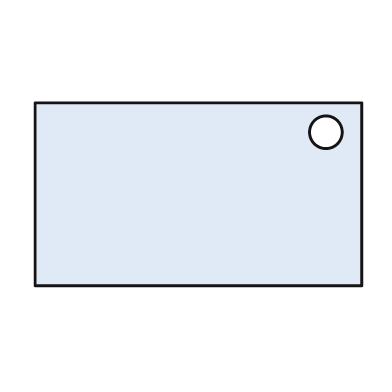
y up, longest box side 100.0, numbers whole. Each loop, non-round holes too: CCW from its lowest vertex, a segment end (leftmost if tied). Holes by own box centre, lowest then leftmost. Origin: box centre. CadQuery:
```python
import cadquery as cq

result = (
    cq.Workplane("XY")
    .moveTo(-50.0, -28.0)
    .lineTo(50.0, -28.0)
    .lineTo(50.0, 28.0)
    .lineTo(-50.0, 28.0)
    .close()
    .moveTo(39.0, 19.0)
    .circle(5.0)
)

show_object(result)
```